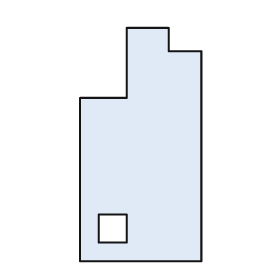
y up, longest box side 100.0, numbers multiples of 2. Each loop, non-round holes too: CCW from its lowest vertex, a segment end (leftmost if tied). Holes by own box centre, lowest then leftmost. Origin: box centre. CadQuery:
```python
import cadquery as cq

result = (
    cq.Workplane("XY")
    .moveTo(-26.0, -50.0)
    .lineTo(26.0, -50.0)
    .lineTo(26.0, 40.0)
    .lineTo(12.0, 40.0)
    .lineTo(12.0, 50.0)
    .lineTo(-6.0, 50.0)
    .lineTo(-6.0, 20.0)
    .lineTo(-26.0, 20.0)
    .close()
    .moveTo(-18.0, -42.0)
    .lineTo(-6.0, -42.0)
    .lineTo(-6.0, -30.0)
    .lineTo(-18.0, -30.0)
    .close()
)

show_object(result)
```